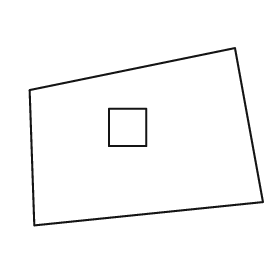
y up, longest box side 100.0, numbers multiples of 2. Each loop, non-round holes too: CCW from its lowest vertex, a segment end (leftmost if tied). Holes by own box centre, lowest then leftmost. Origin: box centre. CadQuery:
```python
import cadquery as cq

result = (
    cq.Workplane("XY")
    .moveTo(-48.0, -38.0)
    .lineTo(50.0, -28.0)
    .lineTo(38.0, 38.0)
    .lineTo(-50.0, 20.0)
    .close()
    .moveTo(-16.0, -4.0)
    .lineTo(0.0, -4.0)
    .lineTo(0.0, 12.0)
    .lineTo(-16.0, 12.0)
    .close()
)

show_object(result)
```